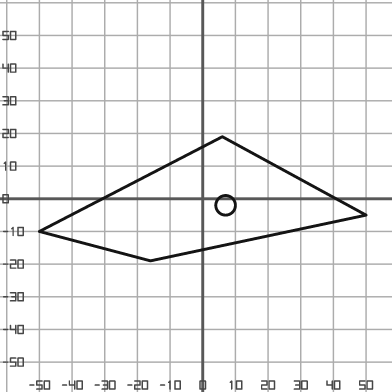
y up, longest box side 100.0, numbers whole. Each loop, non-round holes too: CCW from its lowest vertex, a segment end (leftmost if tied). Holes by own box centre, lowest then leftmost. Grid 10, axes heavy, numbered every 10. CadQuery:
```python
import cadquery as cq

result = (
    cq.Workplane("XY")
    .moveTo(-16.0, -19.0)
    .lineTo(50.0, -5.0)
    .lineTo(6.0, 19.0)
    .lineTo(-50.0, -10.0)
    .close()
    .moveTo(7.0, -2.0)
    .circle(3.0)
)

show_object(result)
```